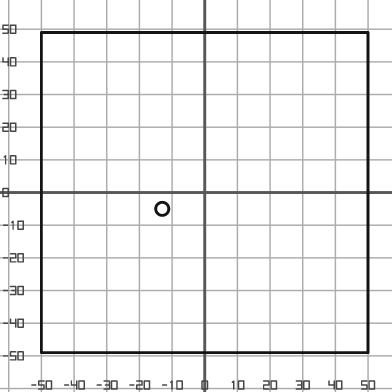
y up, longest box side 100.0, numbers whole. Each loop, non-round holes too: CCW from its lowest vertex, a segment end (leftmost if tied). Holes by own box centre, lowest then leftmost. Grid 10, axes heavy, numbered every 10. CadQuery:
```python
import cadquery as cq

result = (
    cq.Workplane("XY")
    .moveTo(-50.0, -49.0)
    .lineTo(50.0, -49.0)
    .lineTo(50.0, 49.0)
    .lineTo(-50.0, 49.0)
    .close()
    .moveTo(-13.0, -5.0)
    .circle(2.0)
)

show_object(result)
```